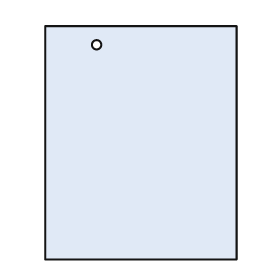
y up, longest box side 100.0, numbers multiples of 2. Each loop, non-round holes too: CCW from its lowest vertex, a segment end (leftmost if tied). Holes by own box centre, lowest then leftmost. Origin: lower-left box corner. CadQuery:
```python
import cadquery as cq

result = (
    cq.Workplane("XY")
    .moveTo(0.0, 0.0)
    .lineTo(82.0, 0.0)
    .lineTo(82.0, 100.0)
    .lineTo(0.0, 100.0)
    .close()
    .moveTo(22.0, 92.0)
    .circle(2.0)
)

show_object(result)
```